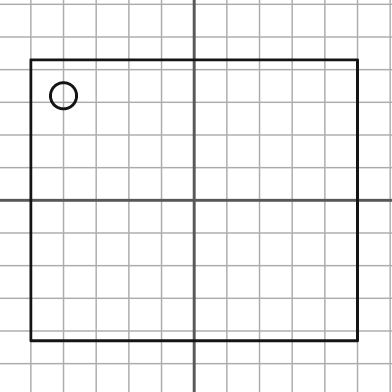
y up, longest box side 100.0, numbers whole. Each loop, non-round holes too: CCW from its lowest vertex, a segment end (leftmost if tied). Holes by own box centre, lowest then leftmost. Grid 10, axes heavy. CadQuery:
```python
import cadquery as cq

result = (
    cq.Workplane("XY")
    .moveTo(-50.0, -43.0)
    .lineTo(50.0, -43.0)
    .lineTo(50.0, 43.0)
    .lineTo(-50.0, 43.0)
    .close()
    .moveTo(-40.0, 32.0)
    .circle(4.0)
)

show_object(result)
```